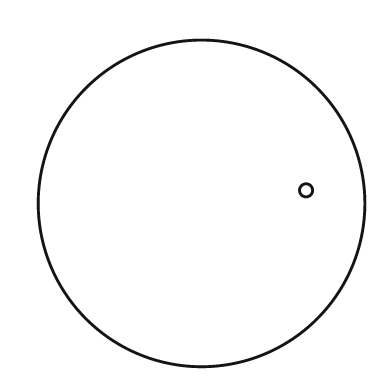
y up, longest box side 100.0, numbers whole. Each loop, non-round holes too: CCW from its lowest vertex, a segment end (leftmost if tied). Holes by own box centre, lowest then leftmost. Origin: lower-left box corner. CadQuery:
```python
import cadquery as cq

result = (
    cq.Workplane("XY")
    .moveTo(50.0, 50.0)
    .circle(50.0)
    .moveTo(82.0, 54.0)
    .circle(2.0)
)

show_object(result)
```